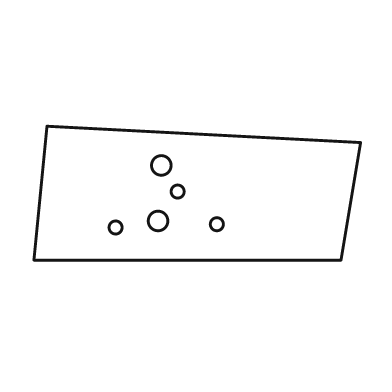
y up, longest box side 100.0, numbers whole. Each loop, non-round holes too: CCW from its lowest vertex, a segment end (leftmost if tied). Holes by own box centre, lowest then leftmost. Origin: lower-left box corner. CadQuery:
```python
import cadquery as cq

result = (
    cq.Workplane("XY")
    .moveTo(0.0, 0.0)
    .lineTo(94.0, 0.0)
    .lineTo(100.0, 36.0)
    .lineTo(4.0, 41.0)
    .close()
    .moveTo(25.0, 10.0)
    .circle(2.0)
    .moveTo(56.0, 11.0)
    .circle(2.0)
    .moveTo(38.0, 12.0)
    .circle(3.0)
    .moveTo(44.0, 21.0)
    .circle(2.0)
    .moveTo(39.0, 29.0)
    .circle(3.0)
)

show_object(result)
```